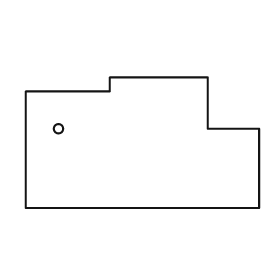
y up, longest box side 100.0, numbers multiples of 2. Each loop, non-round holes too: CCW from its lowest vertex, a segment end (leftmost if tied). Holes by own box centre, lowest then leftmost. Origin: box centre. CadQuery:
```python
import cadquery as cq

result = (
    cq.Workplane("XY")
    .moveTo(-50.0, -28.0)
    .lineTo(50.0, -28.0)
    .lineTo(50.0, 6.0)
    .lineTo(28.0, 6.0)
    .lineTo(28.0, 28.0)
    .lineTo(-14.0, 28.0)
    .lineTo(-14.0, 22.0)
    .lineTo(-50.0, 22.0)
    .close()
    .moveTo(-36.0, 6.0)
    .circle(2.0)
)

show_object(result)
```